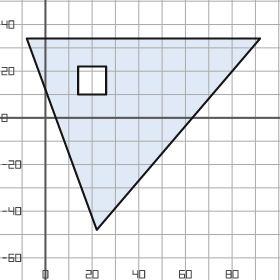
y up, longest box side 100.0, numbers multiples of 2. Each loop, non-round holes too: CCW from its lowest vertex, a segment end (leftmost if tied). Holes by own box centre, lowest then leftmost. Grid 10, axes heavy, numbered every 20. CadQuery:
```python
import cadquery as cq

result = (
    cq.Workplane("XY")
    .moveTo(22.0, -48.0)
    .lineTo(92.0, 34.0)
    .lineTo(-8.0, 34.0)
    .close()
    .moveTo(14.0, 10.0)
    .lineTo(26.0, 10.0)
    .lineTo(26.0, 22.0)
    .lineTo(14.0, 22.0)
    .close()
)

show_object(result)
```